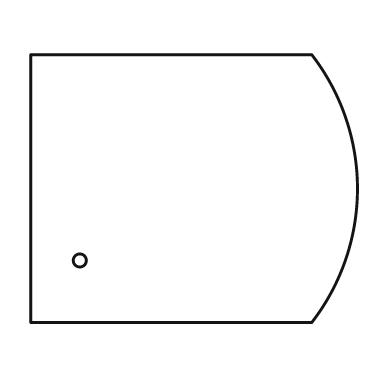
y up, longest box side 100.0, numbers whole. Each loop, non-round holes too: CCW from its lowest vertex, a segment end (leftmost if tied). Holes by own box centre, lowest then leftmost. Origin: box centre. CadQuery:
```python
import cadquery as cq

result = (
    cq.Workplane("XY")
    .moveTo(-50.0, -41.0)
    .lineTo(36.0, -41.0)
    .threePointArc((50.0, 0.0), (36.0, 41.0))
    .lineTo(-50.0, 41.0)
    .close()
    .moveTo(-35.0, -22.0)
    .circle(2.0)
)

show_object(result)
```